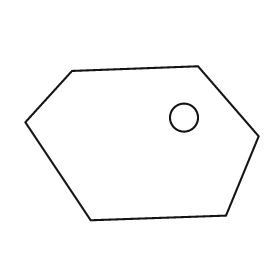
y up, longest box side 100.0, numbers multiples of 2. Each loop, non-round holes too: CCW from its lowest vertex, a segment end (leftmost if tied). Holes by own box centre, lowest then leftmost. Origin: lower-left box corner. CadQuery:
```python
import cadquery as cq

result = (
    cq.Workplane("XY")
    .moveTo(28.0, 0.0)
    .lineTo(86.0, 2.0)
    .lineTo(100.0, 36.0)
    .lineTo(74.0, 66.0)
    .lineTo(20.0, 64.0)
    .lineTo(0.0, 42.0)
    .close()
    .moveTo(68.0, 44.0)
    .circle(6.0)
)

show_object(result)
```